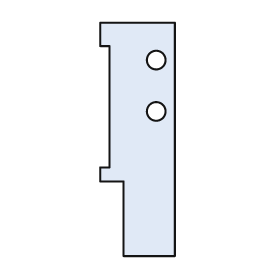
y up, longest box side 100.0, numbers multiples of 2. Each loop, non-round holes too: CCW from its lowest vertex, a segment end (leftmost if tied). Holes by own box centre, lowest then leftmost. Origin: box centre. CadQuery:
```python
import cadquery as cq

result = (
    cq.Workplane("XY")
    .moveTo(-6.0, -50.0)
    .lineTo(16.0, -50.0)
    .lineTo(16.0, 50.0)
    .lineTo(-16.0, 50.0)
    .lineTo(-16.0, 40.0)
    .lineTo(-12.0, 40.0)
    .lineTo(-12.0, -12.0)
    .lineTo(-16.0, -12.0)
    .lineTo(-16.0, -18.0)
    .lineTo(-6.0, -18.0)
    .close()
    .moveTo(8.0, 12.0)
    .circle(4.0)
    .moveTo(8.0, 34.0)
    .circle(4.0)
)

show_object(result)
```